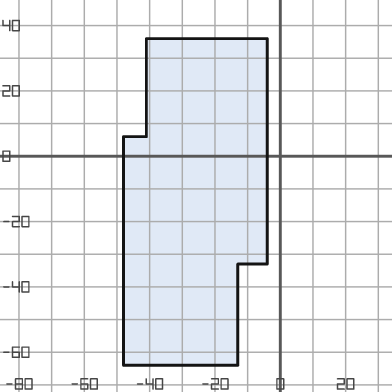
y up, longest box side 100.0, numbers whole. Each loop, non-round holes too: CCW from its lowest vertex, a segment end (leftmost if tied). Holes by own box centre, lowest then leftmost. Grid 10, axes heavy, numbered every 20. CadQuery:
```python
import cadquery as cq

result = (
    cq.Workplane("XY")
    .moveTo(-48.0, -64.0)
    .lineTo(-13.0, -64.0)
    .lineTo(-13.0, -33.0)
    .lineTo(-4.0, -33.0)
    .lineTo(-4.0, 36.0)
    .lineTo(-41.0, 36.0)
    .lineTo(-41.0, 6.0)
    .lineTo(-48.0, 6.0)
    .close()
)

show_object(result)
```